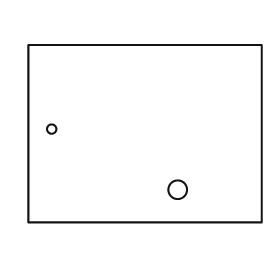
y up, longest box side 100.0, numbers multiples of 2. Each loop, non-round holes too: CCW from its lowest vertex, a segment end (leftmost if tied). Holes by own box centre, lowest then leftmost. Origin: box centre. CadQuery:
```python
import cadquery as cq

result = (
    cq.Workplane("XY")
    .moveTo(-50.0, -38.0)
    .lineTo(50.0, -38.0)
    .lineTo(50.0, 38.0)
    .lineTo(-50.0, 38.0)
    .close()
    .moveTo(14.0, -24.0)
    .circle(4.0)
    .moveTo(-40.0, 2.0)
    .circle(2.0)
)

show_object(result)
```